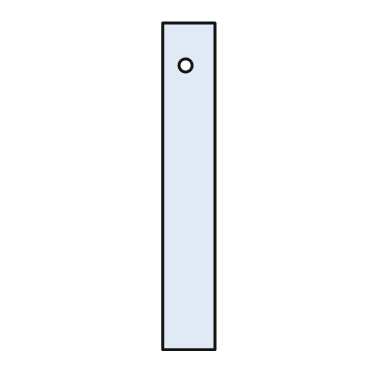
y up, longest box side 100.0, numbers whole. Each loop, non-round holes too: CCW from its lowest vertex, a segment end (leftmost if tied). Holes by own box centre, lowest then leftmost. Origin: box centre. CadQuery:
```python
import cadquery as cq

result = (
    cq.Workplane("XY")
    .moveTo(-8.0, -50.0)
    .lineTo(8.0, -50.0)
    .lineTo(8.0, 50.0)
    .lineTo(-8.0, 50.0)
    .close()
    .moveTo(-1.0, 37.0)
    .circle(2.0)
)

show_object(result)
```